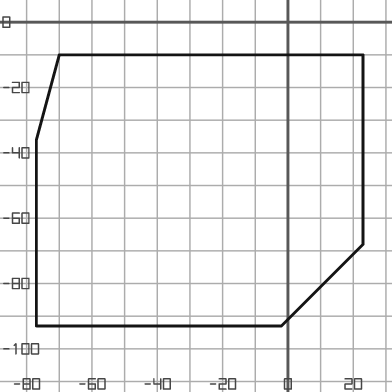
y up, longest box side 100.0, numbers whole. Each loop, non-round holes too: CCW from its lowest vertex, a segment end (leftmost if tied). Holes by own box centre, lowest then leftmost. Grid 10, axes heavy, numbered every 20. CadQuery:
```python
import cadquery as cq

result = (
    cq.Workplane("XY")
    .moveTo(-77.0, -93.0)
    .lineTo(-2.0, -93.0)
    .lineTo(23.0, -68.0)
    .lineTo(23.0, -10.0)
    .lineTo(-70.0, -10.0)
    .lineTo(-77.0, -36.0)
    .close()
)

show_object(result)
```